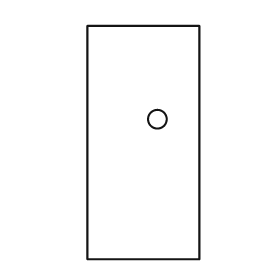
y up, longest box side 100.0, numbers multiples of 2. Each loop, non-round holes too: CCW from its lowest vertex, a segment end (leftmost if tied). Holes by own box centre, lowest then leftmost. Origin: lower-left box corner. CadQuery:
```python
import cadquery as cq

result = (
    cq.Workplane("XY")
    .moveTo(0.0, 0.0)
    .lineTo(48.0, 0.0)
    .lineTo(48.0, 100.0)
    .lineTo(0.0, 100.0)
    .close()
    .moveTo(30.0, 60.0)
    .circle(4.0)
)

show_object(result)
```